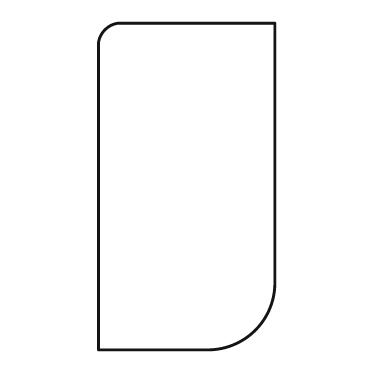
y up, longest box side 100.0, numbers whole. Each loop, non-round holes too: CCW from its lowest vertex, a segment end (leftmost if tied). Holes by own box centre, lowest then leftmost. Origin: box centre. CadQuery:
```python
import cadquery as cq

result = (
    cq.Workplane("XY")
    .moveTo(-27.0, -50.0)
    .lineTo(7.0, -50.0)
    .threePointArc((21.0, -44.0), (27.0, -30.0))
    .lineTo(27.0, 50.0)
    .lineTo(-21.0, 50.0)
    .threePointArc((-25.0, 48.0), (-27.0, 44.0))
    .close()
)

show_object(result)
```